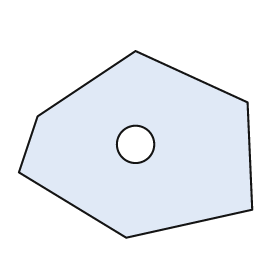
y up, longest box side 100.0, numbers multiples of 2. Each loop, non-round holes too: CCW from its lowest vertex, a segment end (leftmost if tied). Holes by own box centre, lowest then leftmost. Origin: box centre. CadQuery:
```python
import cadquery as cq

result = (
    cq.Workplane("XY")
    .moveTo(-4.0, -40.0)
    .lineTo(50.0, -28.0)
    .lineTo(48.0, 18.0)
    .lineTo(0.0, 40.0)
    .lineTo(-42.0, 12.0)
    .lineTo(-50.0, -12.0)
    .close()
    .moveTo(0.0, 0.0)
    .circle(8.0)
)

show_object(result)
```